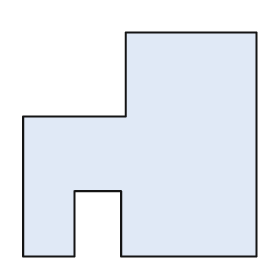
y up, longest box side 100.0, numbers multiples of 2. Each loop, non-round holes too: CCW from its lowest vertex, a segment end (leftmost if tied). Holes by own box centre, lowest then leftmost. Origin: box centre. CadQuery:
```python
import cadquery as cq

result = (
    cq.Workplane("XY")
    .moveTo(-50.0, -48.0)
    .lineTo(-28.0, -48.0)
    .lineTo(-28.0, -20.0)
    .lineTo(-8.0, -20.0)
    .lineTo(-8.0, -48.0)
    .lineTo(50.0, -48.0)
    .lineTo(50.0, 48.0)
    .lineTo(-6.0, 48.0)
    .lineTo(-6.0, 12.0)
    .lineTo(-50.0, 12.0)
    .close()
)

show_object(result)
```